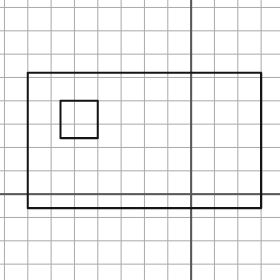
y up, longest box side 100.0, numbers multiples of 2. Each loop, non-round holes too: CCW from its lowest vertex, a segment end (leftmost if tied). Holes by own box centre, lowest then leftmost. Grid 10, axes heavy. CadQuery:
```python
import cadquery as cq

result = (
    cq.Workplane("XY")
    .moveTo(-70.0, -6.0)
    .lineTo(30.0, -6.0)
    .lineTo(30.0, 52.0)
    .lineTo(-70.0, 52.0)
    .close()
    .moveTo(-56.0, 24.0)
    .lineTo(-40.0, 24.0)
    .lineTo(-40.0, 40.0)
    .lineTo(-56.0, 40.0)
    .close()
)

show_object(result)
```